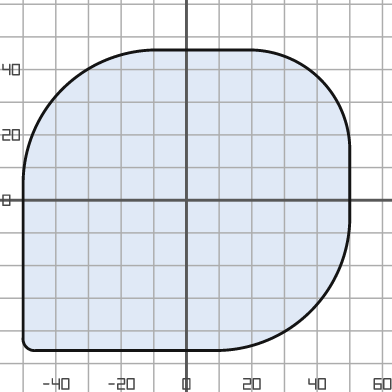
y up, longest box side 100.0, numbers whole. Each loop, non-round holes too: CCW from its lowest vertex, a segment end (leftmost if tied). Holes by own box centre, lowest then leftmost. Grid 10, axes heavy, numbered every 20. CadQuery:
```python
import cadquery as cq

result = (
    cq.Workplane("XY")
    .moveTo(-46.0, -46.0)
    .lineTo(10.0, -46.0)
    .threePointArc((38.0, -34.0), (50.0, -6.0))
    .lineTo(50.0, 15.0)
    .threePointArc((41.0, 37.0), (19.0, 46.0))
    .lineTo(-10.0, 46.0)
    .threePointArc((-38.0, 34.0), (-50.0, 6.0))
    .lineTo(-50.0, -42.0)
    .threePointArc((-49.0, -45.0), (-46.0, -46.0))
    .close()
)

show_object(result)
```